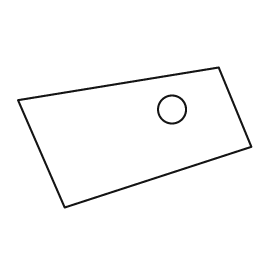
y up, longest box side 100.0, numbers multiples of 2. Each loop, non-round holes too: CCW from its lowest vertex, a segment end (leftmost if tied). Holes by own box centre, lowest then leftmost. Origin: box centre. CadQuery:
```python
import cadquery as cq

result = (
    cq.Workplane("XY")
    .moveTo(-30.0, -30.0)
    .lineTo(50.0, -4.0)
    .lineTo(36.0, 30.0)
    .lineTo(-50.0, 16.0)
    .close()
    .moveTo(16.0, 12.0)
    .circle(6.0)
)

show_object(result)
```